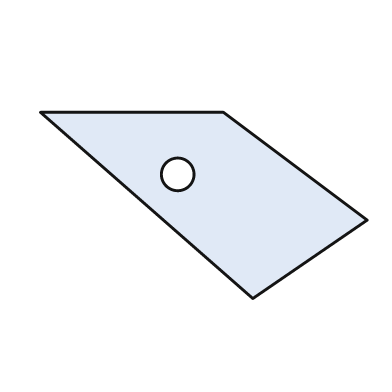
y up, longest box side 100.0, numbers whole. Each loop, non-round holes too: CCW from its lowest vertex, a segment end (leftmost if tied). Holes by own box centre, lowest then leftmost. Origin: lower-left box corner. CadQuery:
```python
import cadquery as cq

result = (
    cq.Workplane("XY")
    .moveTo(65.0, 0.0)
    .lineTo(100.0, 24.0)
    .lineTo(56.0, 57.0)
    .lineTo(0.0, 57.0)
    .close()
    .moveTo(42.0, 38.0)
    .circle(5.0)
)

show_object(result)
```